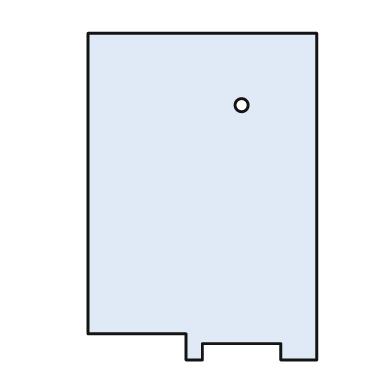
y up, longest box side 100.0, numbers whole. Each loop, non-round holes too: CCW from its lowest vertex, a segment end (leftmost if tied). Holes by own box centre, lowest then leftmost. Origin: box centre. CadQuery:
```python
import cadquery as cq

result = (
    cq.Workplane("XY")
    .moveTo(-5.0, -50.0)
    .lineTo(0.0, -50.0)
    .lineTo(0.0, -45.0)
    .lineTo(24.0, -45.0)
    .lineTo(24.0, -50.0)
    .lineTo(35.0, -50.0)
    .lineTo(35.0, 50.0)
    .lineTo(-35.0, 50.0)
    .lineTo(-35.0, -42.0)
    .lineTo(-5.0, -42.0)
    .close()
    .moveTo(12.0, 28.0)
    .circle(2.0)
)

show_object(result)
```